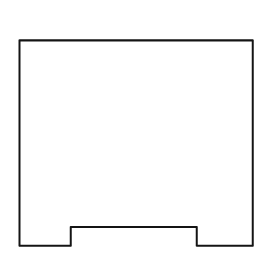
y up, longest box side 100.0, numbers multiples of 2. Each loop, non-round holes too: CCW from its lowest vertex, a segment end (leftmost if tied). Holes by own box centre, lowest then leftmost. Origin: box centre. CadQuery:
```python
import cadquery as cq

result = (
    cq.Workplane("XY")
    .moveTo(-50.0, -44.0)
    .lineTo(-28.0, -44.0)
    .lineTo(-28.0, -36.0)
    .lineTo(26.0, -36.0)
    .lineTo(26.0, -44.0)
    .lineTo(50.0, -44.0)
    .lineTo(50.0, 44.0)
    .lineTo(-50.0, 44.0)
    .close()
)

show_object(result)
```